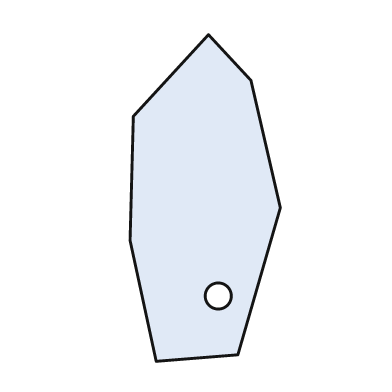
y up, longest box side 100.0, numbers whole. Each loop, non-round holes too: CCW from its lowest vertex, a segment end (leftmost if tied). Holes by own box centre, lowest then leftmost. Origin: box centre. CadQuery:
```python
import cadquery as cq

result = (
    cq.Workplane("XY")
    .moveTo(-15.0, -50.0)
    .lineTo(10.0, -48.0)
    .lineTo(23.0, -3.0)
    .lineTo(14.0, 36.0)
    .lineTo(1.0, 50.0)
    .lineTo(-22.0, 25.0)
    .lineTo(-23.0, -13.0)
    .close()
    .moveTo(4.0, -30.0)
    .circle(4.0)
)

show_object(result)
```